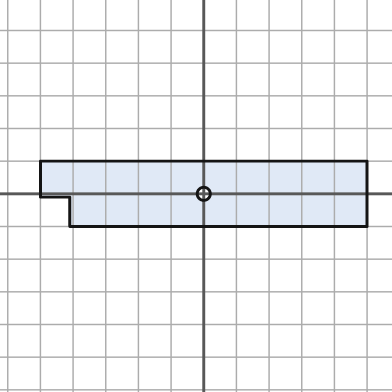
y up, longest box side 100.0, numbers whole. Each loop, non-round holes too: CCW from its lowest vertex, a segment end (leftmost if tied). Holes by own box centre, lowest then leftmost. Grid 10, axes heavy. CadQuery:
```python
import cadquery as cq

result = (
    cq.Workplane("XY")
    .moveTo(-41.0, -10.0)
    .lineTo(50.0, -10.0)
    .lineTo(50.0, 10.0)
    .lineTo(-50.0, 10.0)
    .lineTo(-50.0, -1.0)
    .lineTo(-41.0, -1.0)
    .close()
    .moveTo(0.0, 0.0)
    .circle(2.0)
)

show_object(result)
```